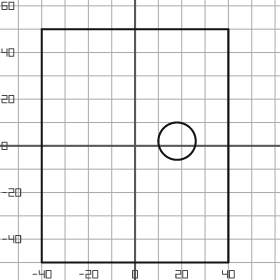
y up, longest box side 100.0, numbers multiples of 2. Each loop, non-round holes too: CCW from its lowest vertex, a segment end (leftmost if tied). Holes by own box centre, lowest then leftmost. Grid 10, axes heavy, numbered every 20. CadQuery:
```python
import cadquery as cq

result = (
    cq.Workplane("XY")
    .moveTo(-40.0, -50.0)
    .lineTo(40.0, -50.0)
    .lineTo(40.0, 50.0)
    .lineTo(-40.0, 50.0)
    .close()
    .moveTo(18.0, 2.0)
    .circle(8.0)
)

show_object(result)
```